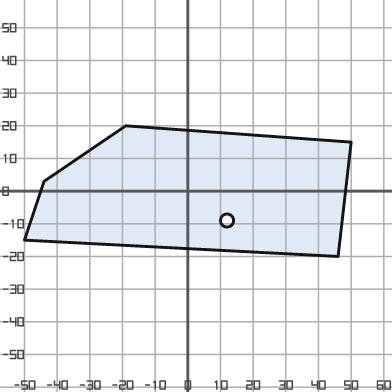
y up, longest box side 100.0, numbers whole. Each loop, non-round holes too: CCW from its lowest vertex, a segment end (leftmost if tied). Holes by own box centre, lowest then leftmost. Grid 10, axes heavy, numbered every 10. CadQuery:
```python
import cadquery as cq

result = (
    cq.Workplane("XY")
    .moveTo(46.0, -20.0)
    .lineTo(50.0, 15.0)
    .lineTo(-19.0, 20.0)
    .lineTo(-44.0, 3.0)
    .lineTo(-50.0, -15.0)
    .close()
    .moveTo(12.0, -9.0)
    .circle(2.0)
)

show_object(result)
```